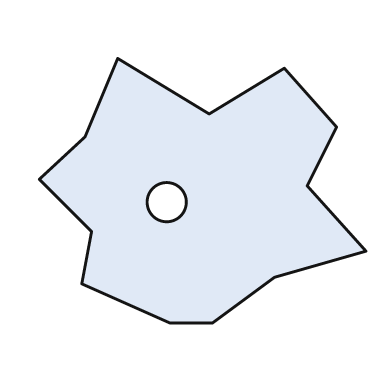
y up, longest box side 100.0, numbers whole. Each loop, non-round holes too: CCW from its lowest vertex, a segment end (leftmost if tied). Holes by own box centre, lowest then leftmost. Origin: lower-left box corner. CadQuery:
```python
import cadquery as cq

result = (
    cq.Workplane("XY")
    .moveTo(40.0, 0.0)
    .lineTo(53.0, 0.0)
    .lineTo(72.0, 14.0)
    .lineTo(100.0, 22.0)
    .lineTo(82.0, 42.0)
    .lineTo(91.0, 60.0)
    .lineTo(75.0, 78.0)
    .lineTo(52.0, 64.0)
    .lineTo(24.0, 81.0)
    .lineTo(14.0, 57.0)
    .lineTo(0.0, 44.0)
    .lineTo(16.0, 28.0)
    .lineTo(13.0, 12.0)
    .close()
    .moveTo(39.0, 37.0)
    .circle(6.0)
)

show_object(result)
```